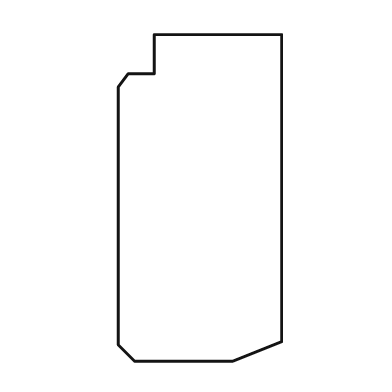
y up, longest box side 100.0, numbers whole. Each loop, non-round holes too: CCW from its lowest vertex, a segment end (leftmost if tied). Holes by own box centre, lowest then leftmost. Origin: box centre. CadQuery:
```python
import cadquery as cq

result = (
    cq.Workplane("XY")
    .moveTo(-20.0, -50.0)
    .lineTo(10.0, -50.0)
    .lineTo(25.0, -44.0)
    .lineTo(25.0, 50.0)
    .lineTo(-14.0, 50.0)
    .lineTo(-14.0, 38.0)
    .lineTo(-22.0, 38.0)
    .lineTo(-25.0, 34.0)
    .lineTo(-25.0, -45.0)
    .close()
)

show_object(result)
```